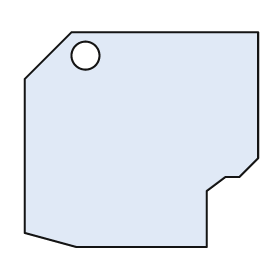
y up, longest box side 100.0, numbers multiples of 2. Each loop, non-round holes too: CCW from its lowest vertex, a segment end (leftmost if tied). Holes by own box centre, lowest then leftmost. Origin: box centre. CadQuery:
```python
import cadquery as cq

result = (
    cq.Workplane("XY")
    .moveTo(-28.0, -46.0)
    .lineTo(28.0, -46.0)
    .lineTo(28.0, -22.0)
    .lineTo(36.0, -16.0)
    .lineTo(42.0, -16.0)
    .lineTo(50.0, -8.0)
    .lineTo(50.0, 46.0)
    .lineTo(-30.0, 46.0)
    .lineTo(-50.0, 26.0)
    .lineTo(-50.0, -40.0)
    .close()
    .moveTo(-24.0, 36.0)
    .circle(6.0)
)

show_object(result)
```